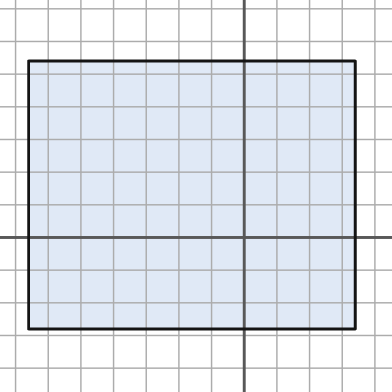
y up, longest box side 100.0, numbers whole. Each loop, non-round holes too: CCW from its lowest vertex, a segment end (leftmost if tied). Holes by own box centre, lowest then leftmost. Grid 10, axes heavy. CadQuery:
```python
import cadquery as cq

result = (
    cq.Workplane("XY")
    .moveTo(-66.0, -28.0)
    .lineTo(34.0, -28.0)
    .lineTo(34.0, 54.0)
    .lineTo(-66.0, 54.0)
    .close()
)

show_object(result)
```